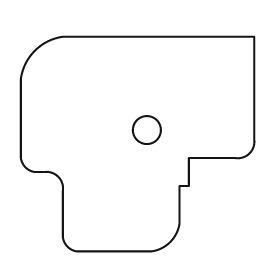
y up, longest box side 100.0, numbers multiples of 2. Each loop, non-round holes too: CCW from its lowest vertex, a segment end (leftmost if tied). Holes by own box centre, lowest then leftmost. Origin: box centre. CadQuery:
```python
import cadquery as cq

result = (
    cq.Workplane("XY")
    .moveTo(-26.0, -46.0)
    .lineTo(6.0, -46.0)
    .threePointArc((14.0, -42.0), (18.0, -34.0))
    .lineTo(18.0, -18.0)
    .lineTo(22.0, -18.0)
    .lineTo(22.0, -6.0)
    .lineTo(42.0, -6.0)
    .threePointArc((48.0, -4.0), (50.0, 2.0))
    .lineTo(50.0, 46.0)
    .lineTo(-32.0, 46.0)
    .threePointArc((-44.0, 40.0), (-50.0, 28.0))
    .lineTo(-50.0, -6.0)
    .threePointArc((-48.0, -10.0), (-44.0, -12.0))
    .lineTo(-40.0, -12.0)
    .threePointArc((-34.0, -14.0), (-32.0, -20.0))
    .lineTo(-32.0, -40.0)
    .threePointArc((-30.0, -44.0), (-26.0, -46.0))
    .close()
    .moveTo(4.0, 6.0)
    .circle(6.0)
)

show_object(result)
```